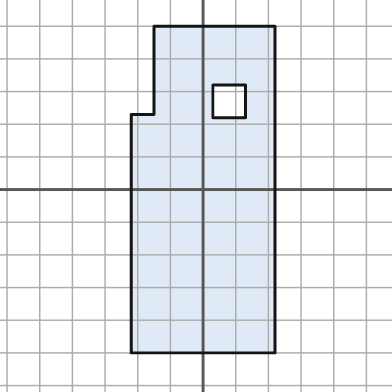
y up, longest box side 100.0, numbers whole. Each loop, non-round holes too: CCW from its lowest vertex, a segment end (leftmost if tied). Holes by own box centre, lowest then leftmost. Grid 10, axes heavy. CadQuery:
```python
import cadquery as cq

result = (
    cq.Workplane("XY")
    .moveTo(-22.0, -50.0)
    .lineTo(22.0, -50.0)
    .lineTo(22.0, 50.0)
    .lineTo(-15.0, 50.0)
    .lineTo(-15.0, 23.0)
    .lineTo(-22.0, 23.0)
    .close()
    .moveTo(3.0, 22.0)
    .lineTo(13.0, 22.0)
    .lineTo(13.0, 32.0)
    .lineTo(3.0, 32.0)
    .close()
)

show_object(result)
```